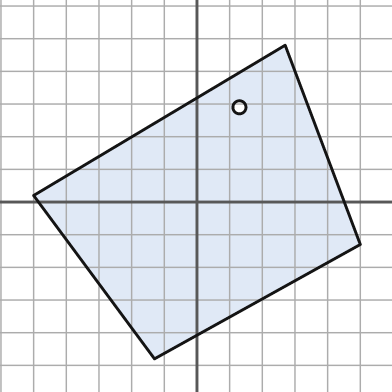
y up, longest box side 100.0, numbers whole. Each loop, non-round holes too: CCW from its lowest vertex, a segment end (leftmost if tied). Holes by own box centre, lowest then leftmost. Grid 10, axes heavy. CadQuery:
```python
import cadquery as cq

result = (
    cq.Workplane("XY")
    .moveTo(-13.0, -48.0)
    .lineTo(50.0, -13.0)
    .lineTo(27.0, 48.0)
    .lineTo(-50.0, 2.0)
    .close()
    .moveTo(13.0, 29.0)
    .circle(2.0)
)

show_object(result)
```